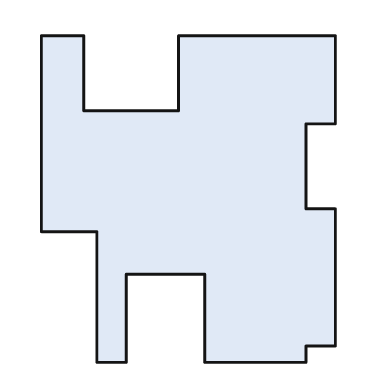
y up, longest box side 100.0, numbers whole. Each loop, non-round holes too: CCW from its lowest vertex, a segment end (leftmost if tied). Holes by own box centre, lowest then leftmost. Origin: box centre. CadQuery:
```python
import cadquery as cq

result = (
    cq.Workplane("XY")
    .moveTo(-28.0, -50.0)
    .lineTo(-19.0, -50.0)
    .lineTo(-19.0, -23.0)
    .lineTo(5.0, -23.0)
    .lineTo(5.0, -50.0)
    .lineTo(36.0, -50.0)
    .lineTo(36.0, -45.0)
    .lineTo(45.0, -45.0)
    .lineTo(45.0, -3.0)
    .lineTo(36.0, -3.0)
    .lineTo(36.0, 23.0)
    .lineTo(45.0, 23.0)
    .lineTo(45.0, 50.0)
    .lineTo(-3.0, 50.0)
    .lineTo(-3.0, 27.0)
    .lineTo(-32.0, 27.0)
    .lineTo(-32.0, 50.0)
    .lineTo(-45.0, 50.0)
    .lineTo(-45.0, -10.0)
    .lineTo(-28.0, -10.0)
    .close()
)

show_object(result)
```